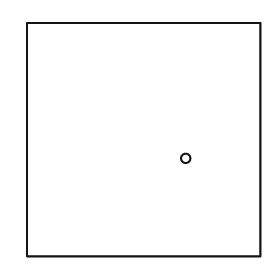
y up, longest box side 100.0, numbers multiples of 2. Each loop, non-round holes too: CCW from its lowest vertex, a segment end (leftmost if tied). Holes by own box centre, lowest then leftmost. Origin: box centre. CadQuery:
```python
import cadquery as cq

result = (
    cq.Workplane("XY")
    .moveTo(-50.0, -50.0)
    .lineTo(50.0, -50.0)
    .lineTo(50.0, 50.0)
    .lineTo(-50.0, 50.0)
    .close()
    .moveTo(18.0, -8.0)
    .circle(2.0)
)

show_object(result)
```